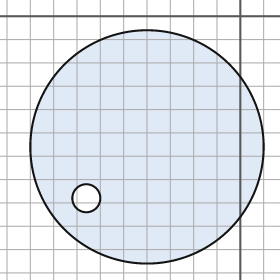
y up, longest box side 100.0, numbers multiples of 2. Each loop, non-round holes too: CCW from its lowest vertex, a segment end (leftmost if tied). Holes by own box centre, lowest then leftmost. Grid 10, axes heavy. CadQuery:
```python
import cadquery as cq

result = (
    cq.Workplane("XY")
    .moveTo(-40.0, -56.0)
    .circle(50.0)
    .moveTo(-66.0, -78.0)
    .circle(6.0)
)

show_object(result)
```